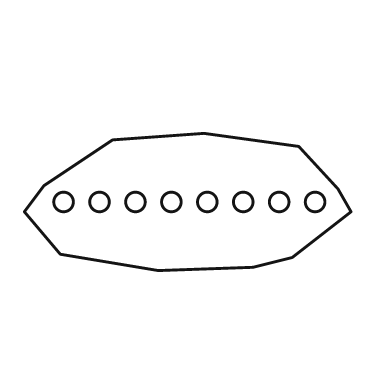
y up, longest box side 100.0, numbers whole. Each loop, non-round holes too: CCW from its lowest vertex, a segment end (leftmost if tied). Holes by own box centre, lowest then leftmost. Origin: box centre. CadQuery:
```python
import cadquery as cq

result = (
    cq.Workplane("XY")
    .moveTo(-9.0, -21.0)
    .lineTo(20.0, -20.0)
    .lineTo(32.0, -17.0)
    .lineTo(50.0, -3.0)
    .lineTo(46.0, 4.0)
    .lineTo(34.0, 17.0)
    .lineTo(5.0, 21.0)
    .lineTo(-23.0, 19.0)
    .lineTo(-44.0, 5.0)
    .lineTo(-50.0, -3.0)
    .lineTo(-39.0, -16.0)
    .close()
    .moveTo(-38.0, 0.0)
    .circle(3.0)
    .moveTo(-27.0, 0.0)
    .circle(3.0)
    .moveTo(-16.0, 0.0)
    .circle(3.0)
    .moveTo(-5.0, 0.0)
    .circle(3.0)
    .moveTo(6.0, 0.0)
    .circle(3.0)
    .moveTo(17.0, 0.0)
    .circle(3.0)
    .moveTo(28.0, 0.0)
    .circle(3.0)
    .moveTo(39.0, 0.0)
    .circle(3.0)
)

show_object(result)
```